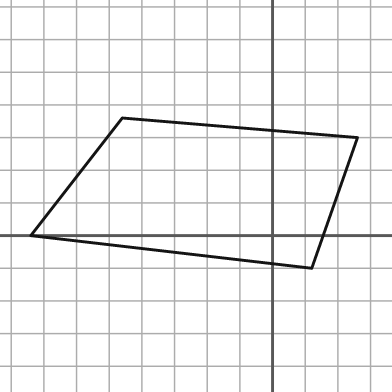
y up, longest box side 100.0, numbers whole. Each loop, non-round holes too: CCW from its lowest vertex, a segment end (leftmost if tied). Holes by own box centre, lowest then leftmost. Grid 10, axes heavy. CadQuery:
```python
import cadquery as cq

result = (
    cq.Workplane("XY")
    .moveTo(12.0, -10.0)
    .lineTo(26.0, 30.0)
    .lineTo(-46.0, 36.0)
    .lineTo(-74.0, 0.0)
    .close()
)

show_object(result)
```